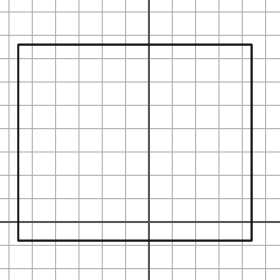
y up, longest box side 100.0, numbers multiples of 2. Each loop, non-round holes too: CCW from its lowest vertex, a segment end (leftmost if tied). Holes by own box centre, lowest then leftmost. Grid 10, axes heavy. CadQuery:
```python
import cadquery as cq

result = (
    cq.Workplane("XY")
    .moveTo(-56.0, -8.0)
    .lineTo(44.0, -8.0)
    .lineTo(44.0, 76.0)
    .lineTo(-56.0, 76.0)
    .close()
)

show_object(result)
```